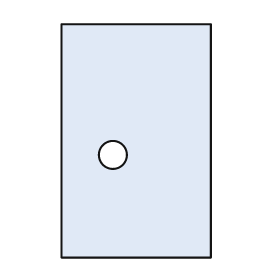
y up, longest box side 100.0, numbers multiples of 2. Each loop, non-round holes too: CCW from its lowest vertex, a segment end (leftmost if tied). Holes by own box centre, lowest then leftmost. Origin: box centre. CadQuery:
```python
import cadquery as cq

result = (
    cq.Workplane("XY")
    .moveTo(-32.0, -50.0)
    .lineTo(32.0, -50.0)
    .lineTo(32.0, 50.0)
    .lineTo(-32.0, 50.0)
    .close()
    .moveTo(-10.0, -6.0)
    .circle(6.0)
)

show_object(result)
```